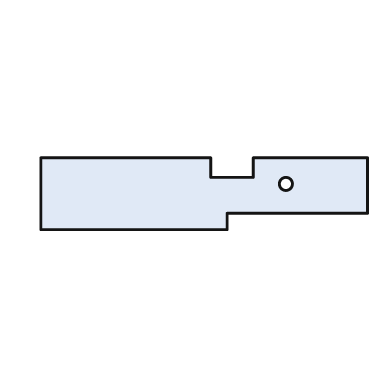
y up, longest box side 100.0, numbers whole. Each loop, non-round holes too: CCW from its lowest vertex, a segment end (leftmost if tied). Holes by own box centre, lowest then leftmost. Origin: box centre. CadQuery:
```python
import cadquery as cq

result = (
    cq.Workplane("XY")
    .moveTo(-50.0, -11.0)
    .lineTo(7.0, -11.0)
    .lineTo(7.0, -6.0)
    .lineTo(50.0, -6.0)
    .lineTo(50.0, 11.0)
    .lineTo(15.0, 11.0)
    .lineTo(15.0, 5.0)
    .lineTo(2.0, 5.0)
    .lineTo(2.0, 11.0)
    .lineTo(-50.0, 11.0)
    .close()
    .moveTo(25.0, 3.0)
    .circle(2.0)
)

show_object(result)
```